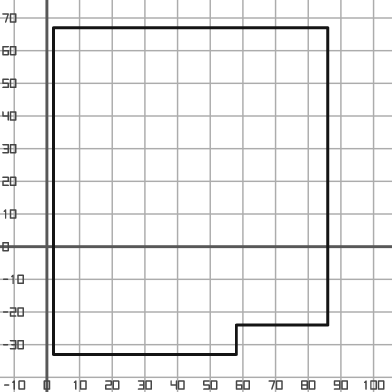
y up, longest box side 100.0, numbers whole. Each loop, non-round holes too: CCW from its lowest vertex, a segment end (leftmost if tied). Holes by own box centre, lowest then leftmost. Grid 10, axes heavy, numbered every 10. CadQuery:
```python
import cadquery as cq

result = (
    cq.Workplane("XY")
    .moveTo(2.0, -33.0)
    .lineTo(58.0, -33.0)
    .lineTo(58.0, -24.0)
    .lineTo(86.0, -24.0)
    .lineTo(86.0, 67.0)
    .lineTo(2.0, 67.0)
    .close()
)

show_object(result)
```